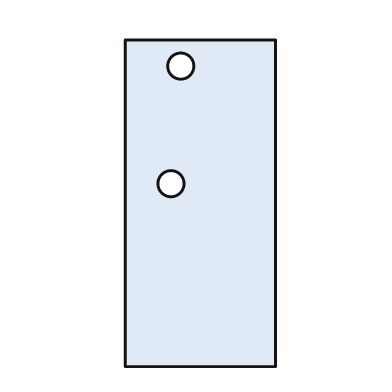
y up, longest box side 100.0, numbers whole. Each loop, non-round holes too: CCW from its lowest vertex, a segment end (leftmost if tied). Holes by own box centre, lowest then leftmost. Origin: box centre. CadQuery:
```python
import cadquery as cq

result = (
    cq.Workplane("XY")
    .moveTo(-23.0, -50.0)
    .lineTo(23.0, -50.0)
    .lineTo(23.0, 50.0)
    .lineTo(-23.0, 50.0)
    .close()
    .moveTo(-9.0, 6.0)
    .circle(4.0)
    .moveTo(-6.0, 42.0)
    .circle(4.0)
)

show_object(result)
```